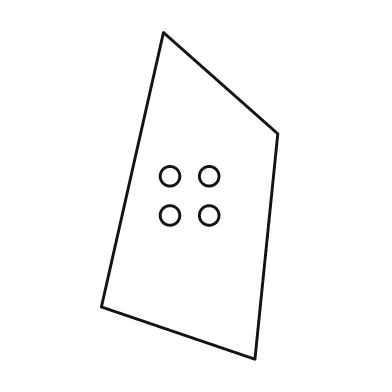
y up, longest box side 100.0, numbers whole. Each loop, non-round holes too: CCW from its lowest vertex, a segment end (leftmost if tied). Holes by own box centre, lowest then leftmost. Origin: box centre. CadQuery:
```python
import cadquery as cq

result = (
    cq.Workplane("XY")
    .moveTo(20.0, -50.0)
    .lineTo(27.0, 19.0)
    .lineTo(-8.0, 50.0)
    .lineTo(-27.0, -34.0)
    .close()
    .moveTo(-6.0, -6.0)
    .circle(3.0)
    .moveTo(6.0, -6.0)
    .circle(3.0)
    .moveTo(-6.0, 6.0)
    .circle(3.0)
    .moveTo(6.0, 6.0)
    .circle(3.0)
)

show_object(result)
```